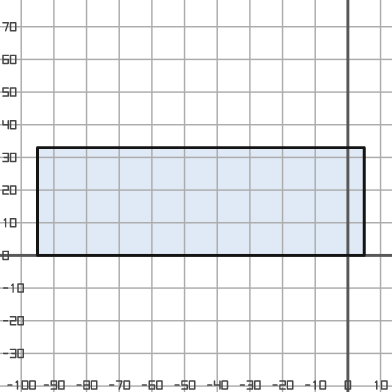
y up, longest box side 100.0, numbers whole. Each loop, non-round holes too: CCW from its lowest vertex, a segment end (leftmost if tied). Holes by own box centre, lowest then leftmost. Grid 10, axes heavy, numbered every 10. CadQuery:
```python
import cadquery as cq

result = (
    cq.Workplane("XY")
    .moveTo(-95.0, 0.0)
    .lineTo(5.0, 0.0)
    .lineTo(5.0, 33.0)
    .lineTo(-95.0, 33.0)
    .close()
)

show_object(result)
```